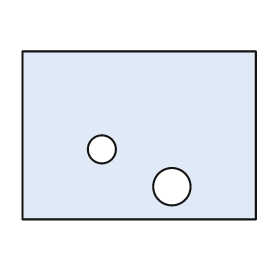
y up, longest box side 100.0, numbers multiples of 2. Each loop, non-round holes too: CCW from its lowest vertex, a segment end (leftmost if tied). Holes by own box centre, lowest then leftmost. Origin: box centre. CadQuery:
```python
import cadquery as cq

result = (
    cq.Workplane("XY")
    .moveTo(-50.0, -36.0)
    .lineTo(50.0, -36.0)
    .lineTo(50.0, 36.0)
    .lineTo(-50.0, 36.0)
    .close()
    .moveTo(14.0, -22.0)
    .circle(8.0)
    .moveTo(-16.0, -6.0)
    .circle(6.0)
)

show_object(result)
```